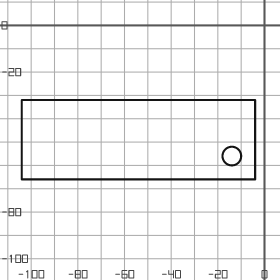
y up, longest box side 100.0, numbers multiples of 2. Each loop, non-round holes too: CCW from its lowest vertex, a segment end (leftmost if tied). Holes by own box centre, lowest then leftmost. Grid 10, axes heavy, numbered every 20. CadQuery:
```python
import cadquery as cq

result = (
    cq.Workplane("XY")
    .moveTo(-104.0, -66.0)
    .lineTo(-4.0, -66.0)
    .lineTo(-4.0, -32.0)
    .lineTo(-104.0, -32.0)
    .close()
    .moveTo(-14.0, -56.0)
    .circle(4.0)
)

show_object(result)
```